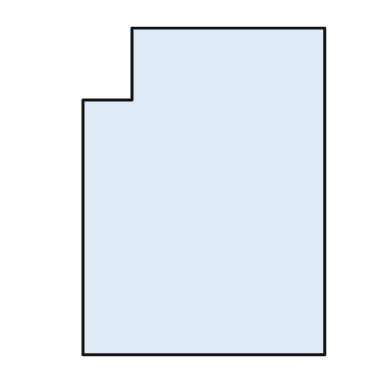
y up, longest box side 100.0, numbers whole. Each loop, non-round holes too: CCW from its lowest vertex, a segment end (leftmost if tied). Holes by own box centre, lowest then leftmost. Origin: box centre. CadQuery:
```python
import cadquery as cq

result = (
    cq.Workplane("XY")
    .moveTo(-37.0, -50.0)
    .lineTo(37.0, -50.0)
    .lineTo(37.0, 50.0)
    .lineTo(-22.0, 50.0)
    .lineTo(-22.0, 28.0)
    .lineTo(-37.0, 28.0)
    .close()
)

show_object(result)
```